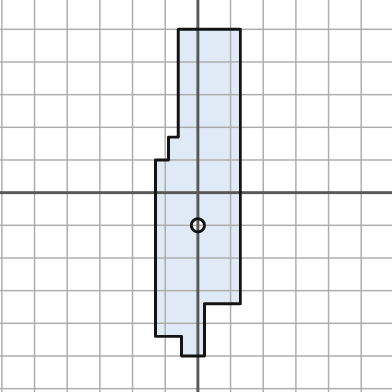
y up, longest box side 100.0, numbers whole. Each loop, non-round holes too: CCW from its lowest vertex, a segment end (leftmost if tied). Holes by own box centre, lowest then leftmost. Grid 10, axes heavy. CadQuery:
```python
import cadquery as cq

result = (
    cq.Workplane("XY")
    .moveTo(-5.0, -50.0)
    .lineTo(2.0, -50.0)
    .lineTo(2.0, -34.0)
    .lineTo(13.0, -34.0)
    .lineTo(13.0, 50.0)
    .lineTo(-6.0, 50.0)
    .lineTo(-6.0, 17.0)
    .lineTo(-9.0, 17.0)
    .lineTo(-9.0, 10.0)
    .lineTo(-13.0, 10.0)
    .lineTo(-13.0, -44.0)
    .lineTo(-5.0, -44.0)
    .close()
    .moveTo(0.0, -10.0)
    .circle(2.0)
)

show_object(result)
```